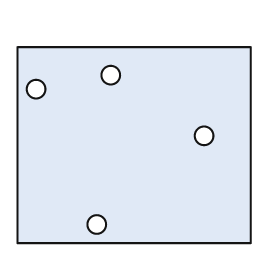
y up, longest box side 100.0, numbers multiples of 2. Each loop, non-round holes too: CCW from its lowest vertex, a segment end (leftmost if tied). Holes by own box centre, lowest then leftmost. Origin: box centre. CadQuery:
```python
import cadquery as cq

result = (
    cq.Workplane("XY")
    .moveTo(-50.0, -42.0)
    .lineTo(50.0, -42.0)
    .lineTo(50.0, 42.0)
    .lineTo(-50.0, 42.0)
    .close()
    .moveTo(-16.0, -34.0)
    .circle(4.0)
    .moveTo(30.0, 4.0)
    .circle(4.0)
    .moveTo(-42.0, 24.0)
    .circle(4.0)
    .moveTo(-10.0, 30.0)
    .circle(4.0)
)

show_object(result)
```